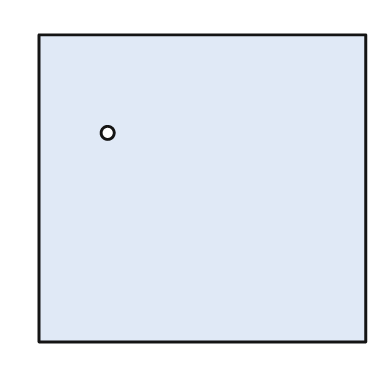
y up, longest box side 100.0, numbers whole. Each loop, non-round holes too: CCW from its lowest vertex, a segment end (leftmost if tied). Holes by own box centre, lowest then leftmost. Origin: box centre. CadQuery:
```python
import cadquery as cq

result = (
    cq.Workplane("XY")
    .moveTo(-50.0, -47.0)
    .lineTo(50.0, -47.0)
    .lineTo(50.0, 47.0)
    .lineTo(-50.0, 47.0)
    .close()
    .moveTo(-29.0, 17.0)
    .circle(2.0)
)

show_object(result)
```